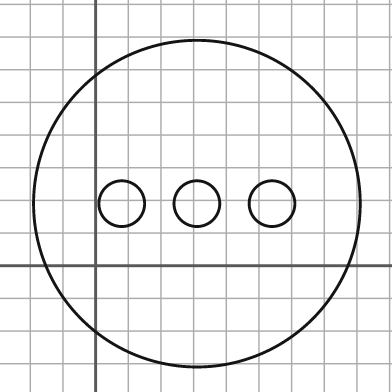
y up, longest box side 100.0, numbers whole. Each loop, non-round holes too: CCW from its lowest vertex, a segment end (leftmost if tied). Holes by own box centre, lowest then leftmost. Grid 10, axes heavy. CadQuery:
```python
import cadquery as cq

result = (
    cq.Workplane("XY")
    .moveTo(31.0, 19.0)
    .circle(50.0)
    .moveTo(8.0, 19.0)
    .circle(7.0)
    .moveTo(31.0, 19.0)
    .circle(7.0)
    .moveTo(54.0, 19.0)
    .circle(7.0)
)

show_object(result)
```